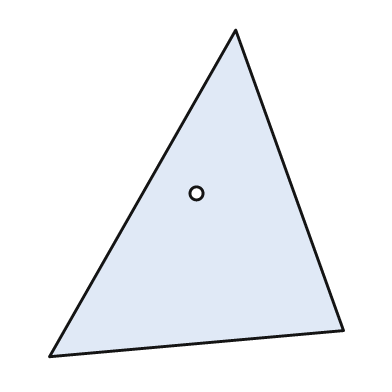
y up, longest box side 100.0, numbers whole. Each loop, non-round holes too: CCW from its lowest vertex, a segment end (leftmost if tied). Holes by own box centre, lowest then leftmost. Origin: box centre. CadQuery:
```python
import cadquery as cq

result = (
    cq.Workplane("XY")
    .moveTo(-45.0, -50.0)
    .lineTo(45.0, -42.0)
    .lineTo(12.0, 50.0)
    .close()
    .moveTo(0.0, 0.0)
    .circle(2.0)
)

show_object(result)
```